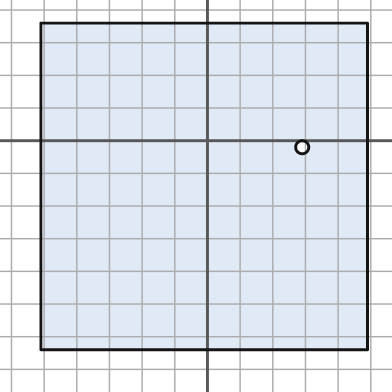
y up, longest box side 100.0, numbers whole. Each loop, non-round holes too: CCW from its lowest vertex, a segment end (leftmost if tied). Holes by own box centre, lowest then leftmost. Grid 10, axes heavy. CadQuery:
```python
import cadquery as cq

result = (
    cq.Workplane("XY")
    .moveTo(-51.0, -64.0)
    .lineTo(49.0, -64.0)
    .lineTo(49.0, 36.0)
    .lineTo(-51.0, 36.0)
    .close()
    .moveTo(29.0, -2.0)
    .circle(2.0)
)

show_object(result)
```